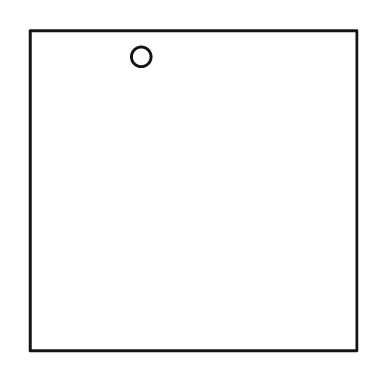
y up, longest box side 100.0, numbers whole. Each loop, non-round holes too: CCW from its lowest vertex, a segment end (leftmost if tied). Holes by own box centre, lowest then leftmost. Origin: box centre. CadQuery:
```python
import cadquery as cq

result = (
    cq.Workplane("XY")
    .moveTo(-50.0, -49.0)
    .lineTo(50.0, -49.0)
    .lineTo(50.0, 49.0)
    .lineTo(-50.0, 49.0)
    .close()
    .moveTo(-16.0, 41.0)
    .circle(3.0)
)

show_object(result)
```